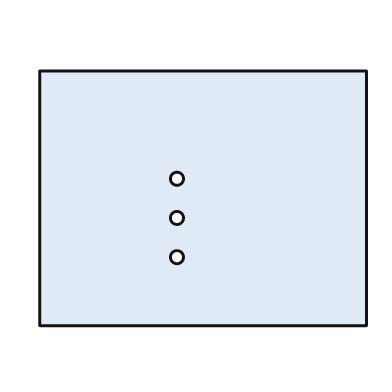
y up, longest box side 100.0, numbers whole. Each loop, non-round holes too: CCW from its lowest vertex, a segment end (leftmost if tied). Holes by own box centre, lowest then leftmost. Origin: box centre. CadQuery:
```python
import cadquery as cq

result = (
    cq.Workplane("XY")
    .moveTo(-50.0, -39.0)
    .lineTo(50.0, -39.0)
    .lineTo(50.0, 39.0)
    .lineTo(-50.0, 39.0)
    .close()
    .moveTo(-8.0, -18.0)
    .circle(2.0)
    .moveTo(-8.0, -6.0)
    .circle(2.0)
    .moveTo(-8.0, 6.0)
    .circle(2.0)
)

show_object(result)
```